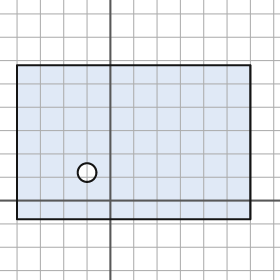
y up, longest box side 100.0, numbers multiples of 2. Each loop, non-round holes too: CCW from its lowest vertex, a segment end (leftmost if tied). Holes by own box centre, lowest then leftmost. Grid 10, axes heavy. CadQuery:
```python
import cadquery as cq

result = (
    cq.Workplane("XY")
    .moveTo(-40.0, -8.0)
    .lineTo(60.0, -8.0)
    .lineTo(60.0, 58.0)
    .lineTo(-40.0, 58.0)
    .close()
    .moveTo(-10.0, 12.0)
    .circle(4.0)
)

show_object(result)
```